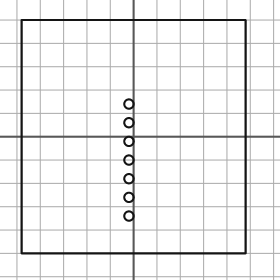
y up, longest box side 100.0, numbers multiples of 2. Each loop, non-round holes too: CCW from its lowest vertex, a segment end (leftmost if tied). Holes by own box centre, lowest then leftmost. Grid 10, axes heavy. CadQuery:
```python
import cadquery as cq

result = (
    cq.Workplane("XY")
    .moveTo(-48.0, -50.0)
    .lineTo(48.0, -50.0)
    .lineTo(48.0, 50.0)
    .lineTo(-48.0, 50.0)
    .close()
    .moveTo(-2.0, -34.0)
    .circle(2.0)
    .moveTo(-2.0, -26.0)
    .circle(2.0)
    .moveTo(-2.0, -18.0)
    .circle(2.0)
    .moveTo(-2.0, -10.0)
    .circle(2.0)
    .moveTo(-2.0, -2.0)
    .circle(2.0)
    .moveTo(-2.0, 6.0)
    .circle(2.0)
    .moveTo(-2.0, 14.0)
    .circle(2.0)
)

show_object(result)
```